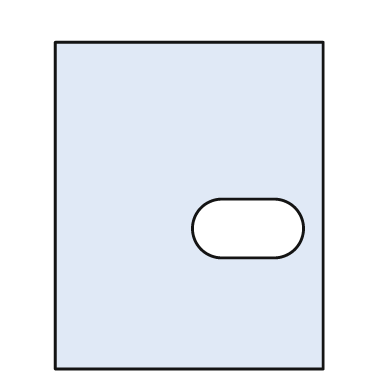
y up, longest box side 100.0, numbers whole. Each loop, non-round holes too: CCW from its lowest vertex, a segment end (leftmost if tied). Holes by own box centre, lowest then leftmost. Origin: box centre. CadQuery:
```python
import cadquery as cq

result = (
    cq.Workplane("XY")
    .moveTo(-41.0, -50.0)
    .lineTo(41.0, -50.0)
    .lineTo(41.0, 50.0)
    .lineTo(-41.0, 50.0)
    .close()
    .moveTo(10.0, -16.0)
    .lineTo(26.0, -16.0)
    .threePointArc((35.0, -7.0), (26.0, 2.0))
    .lineTo(10.0, 2.0)
    .threePointArc((1.0, -7.0), (10.0, -16.0))
    .close()
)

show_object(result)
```